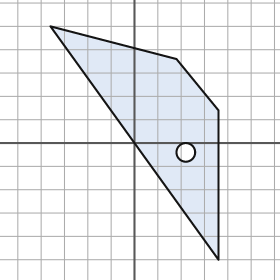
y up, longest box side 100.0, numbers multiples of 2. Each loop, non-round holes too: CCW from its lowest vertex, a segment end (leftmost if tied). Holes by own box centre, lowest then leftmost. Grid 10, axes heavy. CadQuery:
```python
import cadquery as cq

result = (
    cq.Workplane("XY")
    .moveTo(36.0, -50.0)
    .lineTo(36.0, 14.0)
    .lineTo(18.0, 36.0)
    .lineTo(-36.0, 50.0)
    .close()
    .moveTo(22.0, -4.0)
    .circle(4.0)
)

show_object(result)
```